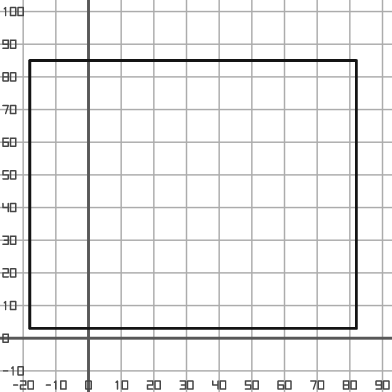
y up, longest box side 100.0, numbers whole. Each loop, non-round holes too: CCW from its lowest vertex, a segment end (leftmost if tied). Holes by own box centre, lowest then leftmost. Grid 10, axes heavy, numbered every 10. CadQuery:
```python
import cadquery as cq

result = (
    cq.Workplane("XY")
    .moveTo(-18.0, 3.0)
    .lineTo(82.0, 3.0)
    .lineTo(82.0, 85.0)
    .lineTo(-18.0, 85.0)
    .close()
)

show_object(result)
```